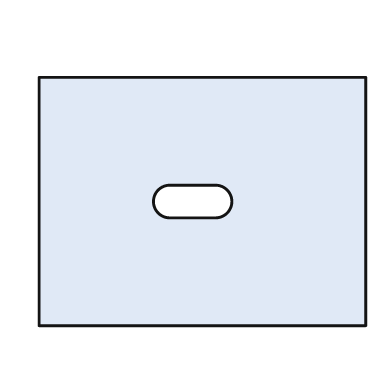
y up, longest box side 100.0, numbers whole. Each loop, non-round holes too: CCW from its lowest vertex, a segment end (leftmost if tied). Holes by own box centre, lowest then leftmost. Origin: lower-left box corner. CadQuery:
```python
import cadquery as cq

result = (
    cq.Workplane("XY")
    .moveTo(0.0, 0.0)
    .lineTo(100.0, 0.0)
    .lineTo(100.0, 76.0)
    .lineTo(0.0, 76.0)
    .close()
    .moveTo(40.0, 33.0)
    .lineTo(54.0, 33.0)
    .threePointArc((59.0, 38.0), (54.0, 43.0))
    .lineTo(40.0, 43.0)
    .threePointArc((35.0, 38.0), (40.0, 33.0))
    .close()
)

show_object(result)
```